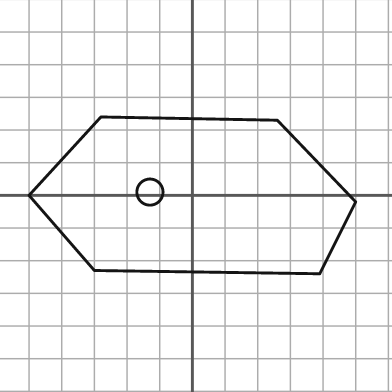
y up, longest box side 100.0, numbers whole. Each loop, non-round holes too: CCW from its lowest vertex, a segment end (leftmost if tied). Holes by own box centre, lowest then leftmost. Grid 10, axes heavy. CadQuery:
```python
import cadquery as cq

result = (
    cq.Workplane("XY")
    .moveTo(39.0, -24.0)
    .lineTo(50.0, -2.0)
    .lineTo(26.0, 23.0)
    .lineTo(-28.0, 24.0)
    .lineTo(-50.0, 0.0)
    .lineTo(-30.0, -23.0)
    .close()
    .moveTo(-13.0, 1.0)
    .circle(4.0)
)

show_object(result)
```